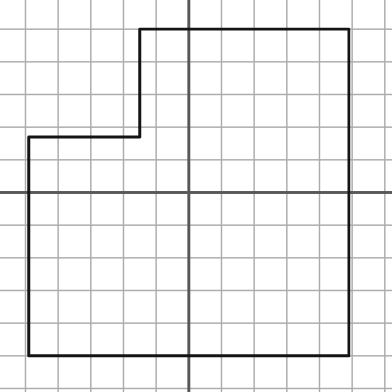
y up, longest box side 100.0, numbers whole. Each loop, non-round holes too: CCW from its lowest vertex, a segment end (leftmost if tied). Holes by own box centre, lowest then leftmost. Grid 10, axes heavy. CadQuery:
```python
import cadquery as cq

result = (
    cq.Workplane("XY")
    .moveTo(-49.0, -50.0)
    .lineTo(49.0, -50.0)
    .lineTo(49.0, 50.0)
    .lineTo(-15.0, 50.0)
    .lineTo(-15.0, 17.0)
    .lineTo(-49.0, 17.0)
    .close()
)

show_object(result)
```